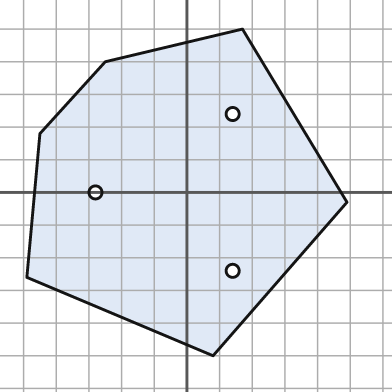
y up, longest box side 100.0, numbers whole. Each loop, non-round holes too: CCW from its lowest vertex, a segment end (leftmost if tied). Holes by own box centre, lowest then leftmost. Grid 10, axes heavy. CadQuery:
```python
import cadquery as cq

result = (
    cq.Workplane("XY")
    .moveTo(8.0, -50.0)
    .lineTo(49.0, -3.0)
    .lineTo(17.0, 50.0)
    .lineTo(-25.0, 40.0)
    .lineTo(-45.0, 18.0)
    .lineTo(-49.0, -26.0)
    .close()
    .moveTo(14.0, -24.0)
    .circle(2.0)
    .moveTo(-28.0, 0.0)
    .circle(2.0)
    .moveTo(14.0, 24.0)
    .circle(2.0)
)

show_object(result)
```